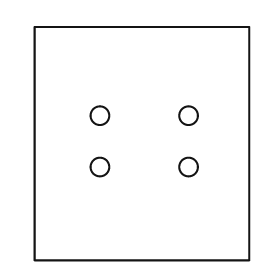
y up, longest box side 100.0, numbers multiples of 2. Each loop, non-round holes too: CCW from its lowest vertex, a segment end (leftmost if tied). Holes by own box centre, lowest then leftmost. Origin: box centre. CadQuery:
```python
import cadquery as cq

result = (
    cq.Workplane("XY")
    .moveTo(-46.0, -50.0)
    .lineTo(46.0, -50.0)
    .lineTo(46.0, 50.0)
    .lineTo(-46.0, 50.0)
    .close()
    .moveTo(-18.0, -10.0)
    .circle(4.0)
    .moveTo(20.0, -10.0)
    .circle(4.0)
    .moveTo(-18.0, 12.0)
    .circle(4.0)
    .moveTo(20.0, 12.0)
    .circle(4.0)
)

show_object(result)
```